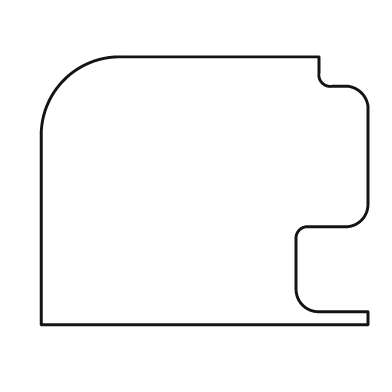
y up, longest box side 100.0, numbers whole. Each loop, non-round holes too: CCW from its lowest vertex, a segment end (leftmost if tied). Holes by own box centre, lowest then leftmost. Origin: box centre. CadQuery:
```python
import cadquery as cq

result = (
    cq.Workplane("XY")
    .moveTo(-50.0, -41.0)
    .lineTo(50.0, -41.0)
    .lineTo(50.0, -37.0)
    .lineTo(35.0, -37.0)
    .threePointArc((30.0, -35.0), (28.0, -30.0))
    .lineTo(28.0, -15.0)
    .threePointArc((29.0, -12.0), (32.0, -11.0))
    .lineTo(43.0, -11.0)
    .threePointArc((48.0, -9.0), (50.0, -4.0))
    .lineTo(50.0, 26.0)
    .threePointArc((48.0, 30.0), (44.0, 32.0))
    .lineTo(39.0, 32.0)
    .threePointArc((36.0, 33.0), (35.0, 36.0))
    .lineTo(35.0, 41.0)
    .lineTo(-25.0, 41.0)
    .threePointArc((-43.0, 34.0), (-50.0, 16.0))
    .close()
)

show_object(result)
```